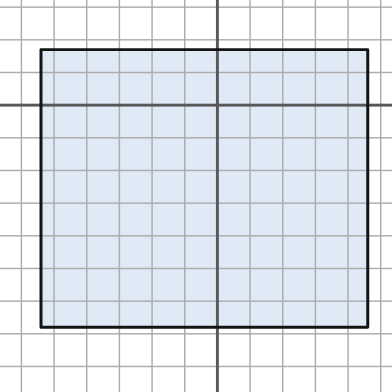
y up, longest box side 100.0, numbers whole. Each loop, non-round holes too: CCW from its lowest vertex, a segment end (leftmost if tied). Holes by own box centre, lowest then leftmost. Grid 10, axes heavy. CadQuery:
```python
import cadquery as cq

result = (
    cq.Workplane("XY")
    .moveTo(-54.0, -68.0)
    .lineTo(46.0, -68.0)
    .lineTo(46.0, 17.0)
    .lineTo(-54.0, 17.0)
    .close()
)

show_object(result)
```